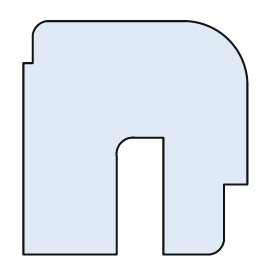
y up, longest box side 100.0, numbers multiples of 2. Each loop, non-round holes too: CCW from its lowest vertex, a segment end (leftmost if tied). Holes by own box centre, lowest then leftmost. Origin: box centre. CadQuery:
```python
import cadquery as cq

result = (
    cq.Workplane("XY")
    .moveTo(-48.0, -50.0)
    .lineTo(-8.0, -50.0)
    .lineTo(-8.0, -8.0)
    .threePointArc((-6.0, -2.0), (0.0, 0.0))
    .lineTo(12.0, 0.0)
    .lineTo(12.0, -50.0)
    .lineTo(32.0, -50.0)
    .threePointArc((36.0, -48.0), (38.0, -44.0))
    .lineTo(38.0, -20.0)
    .lineTo(48.0, -20.0)
    .lineTo(48.0, 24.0)
    .threePointArc((40.0, 42.0), (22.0, 50.0))
    .lineTo(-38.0, 50.0)
    .threePointArc((-42.0, 48.0), (-44.0, 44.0))
    .lineTo(-44.0, 32.0)
    .lineTo(-48.0, 32.0)
    .close()
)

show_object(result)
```